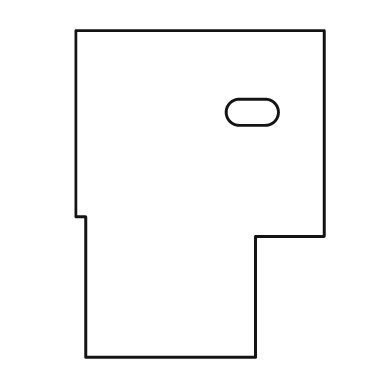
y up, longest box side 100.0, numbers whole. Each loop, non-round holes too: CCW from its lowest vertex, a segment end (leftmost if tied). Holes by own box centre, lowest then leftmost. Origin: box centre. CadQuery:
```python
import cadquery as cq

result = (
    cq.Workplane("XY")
    .moveTo(-35.0, -50.0)
    .lineTo(17.0, -50.0)
    .lineTo(17.0, -13.0)
    .lineTo(38.0, -13.0)
    .lineTo(38.0, 50.0)
    .lineTo(-38.0, 50.0)
    .lineTo(-38.0, -7.0)
    .lineTo(-35.0, -7.0)
    .close()
    .moveTo(12.0, 21.0)
    .lineTo(20.0, 21.0)
    .threePointArc((24.0, 25.0), (20.0, 29.0))
    .lineTo(12.0, 29.0)
    .threePointArc((8.0, 25.0), (12.0, 21.0))
    .close()
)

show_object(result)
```